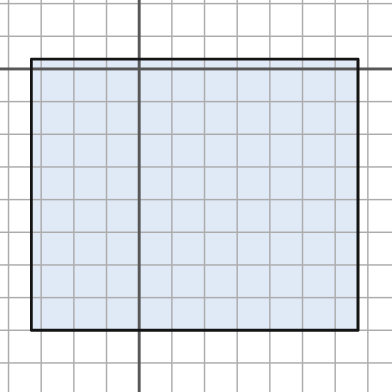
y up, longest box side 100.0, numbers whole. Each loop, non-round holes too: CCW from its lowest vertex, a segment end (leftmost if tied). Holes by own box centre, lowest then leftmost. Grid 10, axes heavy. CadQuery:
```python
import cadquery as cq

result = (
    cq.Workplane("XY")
    .moveTo(-33.0, -80.0)
    .lineTo(67.0, -80.0)
    .lineTo(67.0, 3.0)
    .lineTo(-33.0, 3.0)
    .close()
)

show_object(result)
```